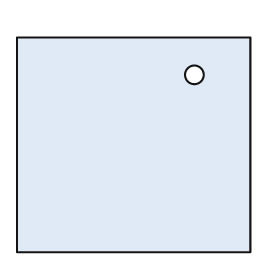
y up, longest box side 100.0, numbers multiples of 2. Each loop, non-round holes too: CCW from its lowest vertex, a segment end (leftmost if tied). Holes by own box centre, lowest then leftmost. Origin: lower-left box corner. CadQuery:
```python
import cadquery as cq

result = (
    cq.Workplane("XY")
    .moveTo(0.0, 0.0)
    .lineTo(100.0, 0.0)
    .lineTo(100.0, 92.0)
    .lineTo(0.0, 92.0)
    .close()
    .moveTo(76.0, 76.0)
    .circle(4.0)
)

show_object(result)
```